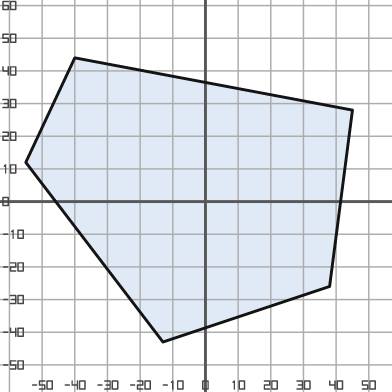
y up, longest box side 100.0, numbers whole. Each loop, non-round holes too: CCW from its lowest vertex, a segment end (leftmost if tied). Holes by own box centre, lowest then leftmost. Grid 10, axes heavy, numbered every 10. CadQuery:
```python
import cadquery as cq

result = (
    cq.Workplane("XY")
    .moveTo(-13.0, -43.0)
    .lineTo(38.0, -26.0)
    .lineTo(45.0, 28.0)
    .lineTo(-40.0, 44.0)
    .lineTo(-55.0, 12.0)
    .close()
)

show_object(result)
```